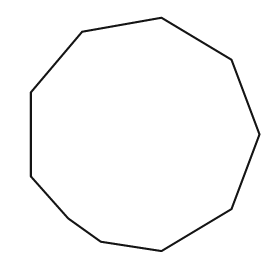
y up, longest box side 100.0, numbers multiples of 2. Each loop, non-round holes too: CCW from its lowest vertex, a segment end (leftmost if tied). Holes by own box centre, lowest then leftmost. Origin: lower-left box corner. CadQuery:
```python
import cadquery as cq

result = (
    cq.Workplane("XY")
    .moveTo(56.0, 0.0)
    .lineTo(86.0, 18.0)
    .lineTo(98.0, 50.0)
    .lineTo(86.0, 82.0)
    .lineTo(56.0, 100.0)
    .lineTo(22.0, 94.0)
    .lineTo(0.0, 68.0)
    .lineTo(0.0, 32.0)
    .lineTo(16.0, 14.0)
    .lineTo(30.0, 4.0)
    .close()
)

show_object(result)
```